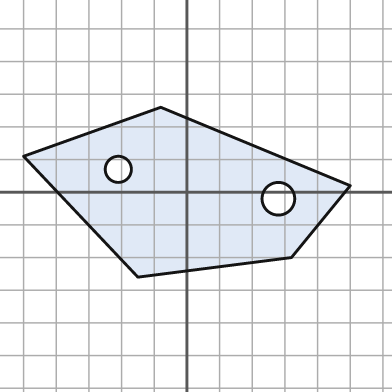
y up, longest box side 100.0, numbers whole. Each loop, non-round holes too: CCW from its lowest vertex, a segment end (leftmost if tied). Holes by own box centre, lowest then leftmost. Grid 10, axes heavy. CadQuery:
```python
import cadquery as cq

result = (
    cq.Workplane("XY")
    .moveTo(-15.0, -26.0)
    .lineTo(32.0, -20.0)
    .lineTo(50.0, 2.0)
    .lineTo(-8.0, 26.0)
    .lineTo(-50.0, 11.0)
    .close()
    .moveTo(28.0, -2.0)
    .circle(5.0)
    .moveTo(-21.0, 7.0)
    .circle(4.0)
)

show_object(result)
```